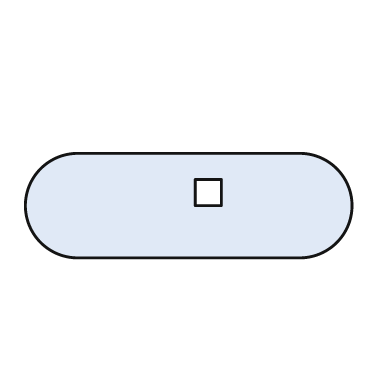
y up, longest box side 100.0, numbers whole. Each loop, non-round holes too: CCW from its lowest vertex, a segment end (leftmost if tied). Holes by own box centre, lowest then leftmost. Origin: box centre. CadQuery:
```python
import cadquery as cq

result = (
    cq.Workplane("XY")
    .moveTo(-34.0, -16.0)
    .lineTo(34.0, -16.0)
    .threePointArc((50.0, 0.0), (34.0, 16.0))
    .lineTo(-34.0, 16.0)
    .threePointArc((-50.0, 0.0), (-34.0, -16.0))
    .close()
    .moveTo(2.0, 0.0)
    .lineTo(10.0, 0.0)
    .lineTo(10.0, 8.0)
    .lineTo(2.0, 8.0)
    .close()
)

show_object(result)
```